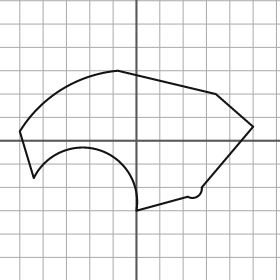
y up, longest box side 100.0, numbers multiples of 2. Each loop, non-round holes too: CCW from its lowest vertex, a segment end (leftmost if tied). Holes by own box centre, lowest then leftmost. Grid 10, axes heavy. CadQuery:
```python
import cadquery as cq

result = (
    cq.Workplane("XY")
    .moveTo(0.0, -30.0)
    .lineTo(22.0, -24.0)
    .threePointArc((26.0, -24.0), (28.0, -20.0))
    .lineTo(50.0, 6.0)
    .lineTo(34.0, 20.0)
    .lineTo(-8.0, 30.0)
    .threePointArc((-32.0, 22.0), (-50.0, 4.0))
    .lineTo(-44.0, -16.0)
    .threePointArc((-16.0, -4.0), (0.0, -30.0))
    .close()
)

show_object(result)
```